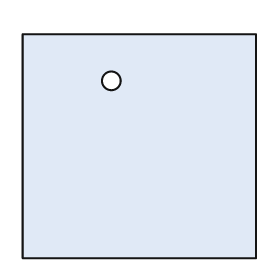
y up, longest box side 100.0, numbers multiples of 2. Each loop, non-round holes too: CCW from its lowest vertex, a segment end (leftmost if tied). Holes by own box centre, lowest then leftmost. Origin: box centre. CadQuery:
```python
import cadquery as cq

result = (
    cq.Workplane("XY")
    .moveTo(-50.0, -48.0)
    .lineTo(50.0, -48.0)
    .lineTo(50.0, 48.0)
    .lineTo(-50.0, 48.0)
    .close()
    .moveTo(-12.0, 28.0)
    .circle(4.0)
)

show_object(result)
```